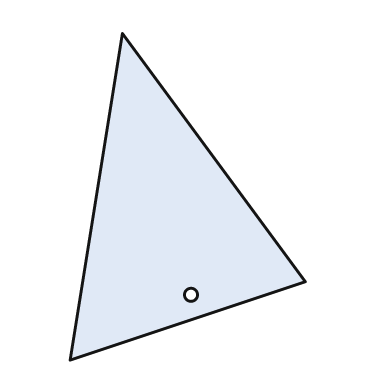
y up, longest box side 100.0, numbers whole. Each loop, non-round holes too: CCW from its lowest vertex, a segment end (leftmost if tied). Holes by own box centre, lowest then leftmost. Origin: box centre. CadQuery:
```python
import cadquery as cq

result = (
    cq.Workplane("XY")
    .moveTo(-36.0, -50.0)
    .lineTo(36.0, -26.0)
    .lineTo(-20.0, 50.0)
    .close()
    .moveTo(1.0, -30.0)
    .circle(2.0)
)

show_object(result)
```